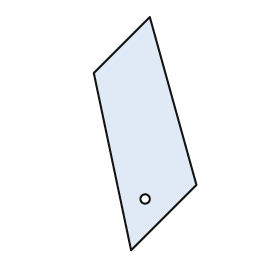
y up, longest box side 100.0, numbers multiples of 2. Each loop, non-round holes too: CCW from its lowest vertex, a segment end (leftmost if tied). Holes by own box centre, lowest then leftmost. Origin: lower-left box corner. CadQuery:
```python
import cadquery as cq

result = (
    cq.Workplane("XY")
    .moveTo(16.0, 0.0)
    .lineTo(44.0, 28.0)
    .lineTo(24.0, 100.0)
    .lineTo(0.0, 76.0)
    .close()
    .moveTo(22.0, 22.0)
    .circle(2.0)
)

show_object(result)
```